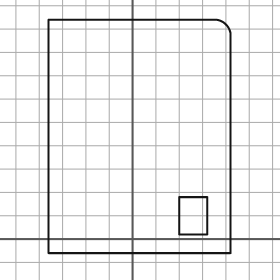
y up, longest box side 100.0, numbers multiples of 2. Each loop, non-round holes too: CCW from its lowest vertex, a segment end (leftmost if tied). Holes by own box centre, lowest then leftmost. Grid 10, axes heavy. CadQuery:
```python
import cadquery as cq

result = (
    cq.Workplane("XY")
    .moveTo(-36.0, -6.0)
    .lineTo(42.0, -6.0)
    .lineTo(42.0, 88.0)
    .threePointArc((40.0, 92.0), (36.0, 94.0))
    .lineTo(-36.0, 94.0)
    .close()
    .moveTo(20.0, 2.0)
    .lineTo(32.0, 2.0)
    .lineTo(32.0, 18.0)
    .lineTo(20.0, 18.0)
    .close()
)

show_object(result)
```